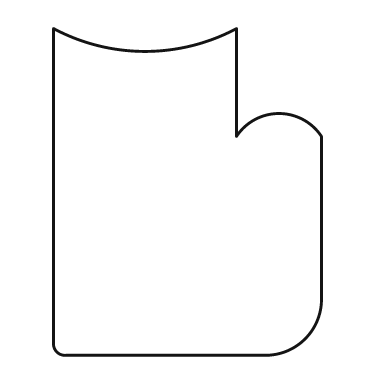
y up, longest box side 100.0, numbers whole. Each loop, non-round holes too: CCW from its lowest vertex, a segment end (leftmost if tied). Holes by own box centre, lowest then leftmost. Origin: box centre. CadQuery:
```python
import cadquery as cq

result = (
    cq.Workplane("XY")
    .moveTo(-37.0, -50.0)
    .lineTo(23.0, -50.0)
    .threePointArc((36.0, -45.0), (41.0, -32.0))
    .lineTo(41.0, 17.0)
    .threePointArc((28.0, 24.0), (15.0, 17.0))
    .lineTo(15.0, 50.0)
    .threePointArc((-13.0, 43.0), (-41.0, 50.0))
    .lineTo(-41.0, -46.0)
    .threePointArc((-40.0, -49.0), (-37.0, -50.0))
    .close()
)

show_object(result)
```